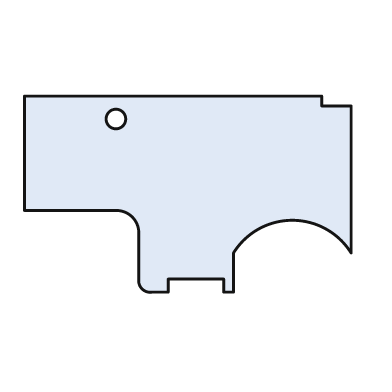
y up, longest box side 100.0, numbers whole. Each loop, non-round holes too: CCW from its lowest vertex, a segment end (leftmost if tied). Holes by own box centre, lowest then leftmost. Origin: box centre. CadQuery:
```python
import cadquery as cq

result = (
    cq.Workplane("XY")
    .moveTo(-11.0, -30.0)
    .lineTo(-6.0, -30.0)
    .lineTo(-6.0, -26.0)
    .lineTo(11.0, -26.0)
    .lineTo(11.0, -30.0)
    .lineTo(14.0, -30.0)
    .lineTo(14.0, -18.0)
    .threePointArc((32.0, -8.0), (50.0, -18.0))
    .lineTo(50.0, 27.0)
    .lineTo(41.0, 27.0)
    .lineTo(41.0, 30.0)
    .lineTo(-50.0, 30.0)
    .lineTo(-50.0, -5.0)
    .lineTo(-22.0, -5.0)
    .threePointArc((-17.0, -7.0), (-15.0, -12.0))
    .lineTo(-15.0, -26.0)
    .threePointArc((-14.0, -29.0), (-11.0, -30.0))
    .close()
    .moveTo(-22.0, 23.0)
    .circle(3.0)
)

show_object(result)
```